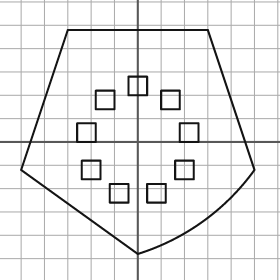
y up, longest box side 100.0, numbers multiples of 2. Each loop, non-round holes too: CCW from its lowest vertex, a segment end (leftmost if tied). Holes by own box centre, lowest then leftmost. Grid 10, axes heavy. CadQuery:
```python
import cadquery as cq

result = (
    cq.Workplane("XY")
    .moveTo(0.0, -48.0)
    .threePointArc((28.0, -34.0), (50.0, -12.0))
    .lineTo(30.0, 48.0)
    .lineTo(-30.0, 48.0)
    .lineTo(-50.0, -12.0)
    .close()
    .moveTo(-12.0, -26.0)
    .lineTo(-4.0, -26.0)
    .lineTo(-4.0, -18.0)
    .lineTo(-12.0, -18.0)
    .close()
    .moveTo(4.0, -26.0)
    .lineTo(12.0, -26.0)
    .lineTo(12.0, -18.0)
    .lineTo(4.0, -18.0)
    .close()
    .moveTo(-24.0, -16.0)
    .lineTo(-16.0, -16.0)
    .lineTo(-16.0, -8.0)
    .lineTo(-24.0, -8.0)
    .close()
    .moveTo(16.0, -16.0)
    .lineTo(24.0, -16.0)
    .lineTo(24.0, -8.0)
    .lineTo(16.0, -8.0)
    .close()
    .moveTo(-26.0, 0.0)
    .lineTo(-18.0, 0.0)
    .lineTo(-18.0, 8.0)
    .lineTo(-26.0, 8.0)
    .close()
    .moveTo(18.0, 0.0)
    .lineTo(26.0, 0.0)
    .lineTo(26.0, 8.0)
    .lineTo(18.0, 8.0)
    .close()
    .moveTo(-18.0, 14.0)
    .lineTo(-10.0, 14.0)
    .lineTo(-10.0, 22.0)
    .lineTo(-18.0, 22.0)
    .close()
    .moveTo(10.0, 14.0)
    .lineTo(18.0, 14.0)
    .lineTo(18.0, 22.0)
    .lineTo(10.0, 22.0)
    .close()
    .moveTo(-4.0, 20.0)
    .lineTo(4.0, 20.0)
    .lineTo(4.0, 28.0)
    .lineTo(-4.0, 28.0)
    .close()
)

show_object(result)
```